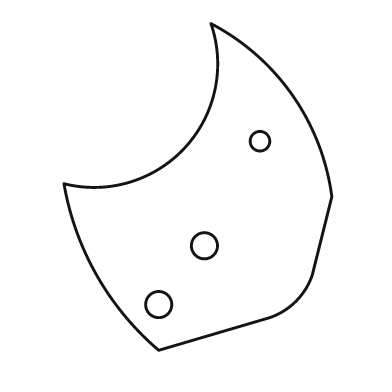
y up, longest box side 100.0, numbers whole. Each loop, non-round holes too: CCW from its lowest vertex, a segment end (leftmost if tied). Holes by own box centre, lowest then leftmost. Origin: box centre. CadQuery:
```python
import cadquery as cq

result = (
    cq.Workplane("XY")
    .moveTo(-12.0, -50.0)
    .lineTo(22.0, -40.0)
    .threePointArc((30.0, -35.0), (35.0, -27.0))
    .lineTo(41.0, -3.0)
    .threePointArc((29.0, 28.0), (4.0, 50.0))
    .threePointArc((-4.0, 12.0), (-41.0, 1.0))
    .threePointArc((-31.0, -27.0), (-12.0, -50.0))
    .close()
    .moveTo(-12.0, -36.0)
    .circle(4.0)
    .moveTo(2.0, -18.0)
    .circle(4.0)
    .moveTo(19.0, 14.0)
    .circle(3.0)
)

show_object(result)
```